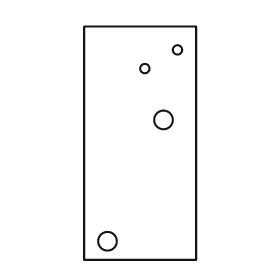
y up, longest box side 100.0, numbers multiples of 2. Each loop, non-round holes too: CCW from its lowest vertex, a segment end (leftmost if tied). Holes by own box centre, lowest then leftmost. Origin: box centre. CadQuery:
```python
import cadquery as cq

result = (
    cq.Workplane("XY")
    .moveTo(-24.0, -50.0)
    .lineTo(24.0, -50.0)
    .lineTo(24.0, 50.0)
    .lineTo(-24.0, 50.0)
    .close()
    .moveTo(-14.0, -42.0)
    .circle(4.0)
    .moveTo(10.0, 10.0)
    .circle(4.0)
    .moveTo(2.0, 32.0)
    .circle(2.0)
    .moveTo(16.0, 40.0)
    .circle(2.0)
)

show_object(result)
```